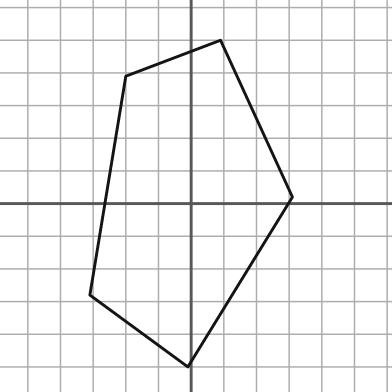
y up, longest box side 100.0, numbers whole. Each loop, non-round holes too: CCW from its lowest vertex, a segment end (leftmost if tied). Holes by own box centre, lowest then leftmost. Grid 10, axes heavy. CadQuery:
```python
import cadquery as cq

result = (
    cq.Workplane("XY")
    .moveTo(-1.0, -50.0)
    .lineTo(31.0, 2.0)
    .lineTo(9.0, 50.0)
    .lineTo(-20.0, 39.0)
    .lineTo(-31.0, -28.0)
    .close()
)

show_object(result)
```